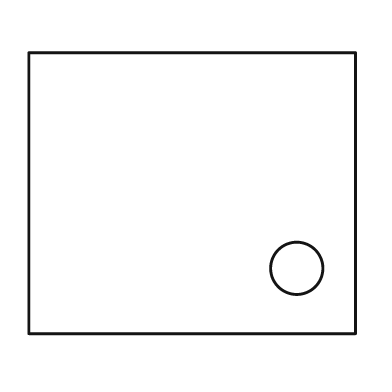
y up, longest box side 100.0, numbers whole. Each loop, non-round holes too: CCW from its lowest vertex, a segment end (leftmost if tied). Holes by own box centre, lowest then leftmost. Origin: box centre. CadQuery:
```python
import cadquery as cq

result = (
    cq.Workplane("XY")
    .moveTo(-50.0, -43.0)
    .lineTo(50.0, -43.0)
    .lineTo(50.0, 43.0)
    .lineTo(-50.0, 43.0)
    .close()
    .moveTo(32.0, -23.0)
    .circle(8.0)
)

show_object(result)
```